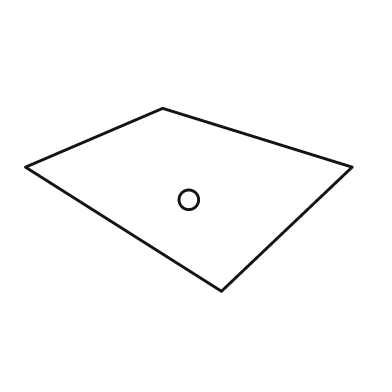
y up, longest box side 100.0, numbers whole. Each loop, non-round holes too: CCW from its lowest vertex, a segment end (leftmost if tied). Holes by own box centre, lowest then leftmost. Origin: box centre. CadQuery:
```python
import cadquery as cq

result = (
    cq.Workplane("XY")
    .moveTo(10.0, -28.0)
    .lineTo(50.0, 10.0)
    .lineTo(-8.0, 28.0)
    .lineTo(-50.0, 10.0)
    .close()
    .moveTo(0.0, 0.0)
    .circle(3.0)
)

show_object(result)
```